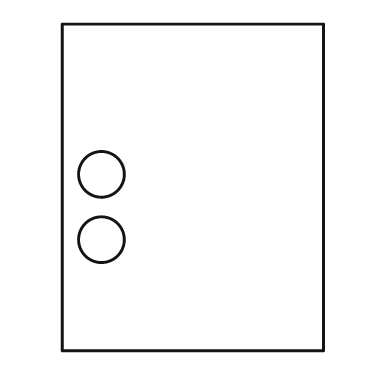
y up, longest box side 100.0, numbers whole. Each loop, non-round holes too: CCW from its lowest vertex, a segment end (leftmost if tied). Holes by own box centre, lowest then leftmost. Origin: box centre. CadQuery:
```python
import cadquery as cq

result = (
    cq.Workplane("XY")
    .moveTo(-40.0, -50.0)
    .lineTo(40.0, -50.0)
    .lineTo(40.0, 50.0)
    .lineTo(-40.0, 50.0)
    .close()
    .moveTo(-28.0, -16.0)
    .circle(7.0)
    .moveTo(-28.0, 4.0)
    .circle(7.0)
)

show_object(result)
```